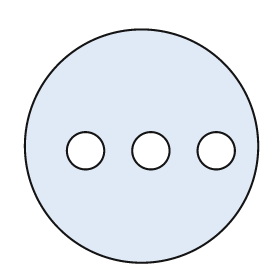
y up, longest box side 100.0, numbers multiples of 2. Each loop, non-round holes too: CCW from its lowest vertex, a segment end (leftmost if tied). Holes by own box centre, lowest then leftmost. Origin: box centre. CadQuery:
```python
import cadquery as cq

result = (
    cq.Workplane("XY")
    .moveTo(0.0, 0.0)
    .circle(50.0)
    .moveTo(-24.0, -2.0)
    .circle(8.0)
    .moveTo(4.0, -2.0)
    .circle(8.0)
    .moveTo(32.0, -2.0)
    .circle(8.0)
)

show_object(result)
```